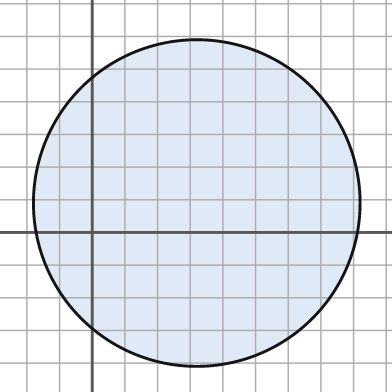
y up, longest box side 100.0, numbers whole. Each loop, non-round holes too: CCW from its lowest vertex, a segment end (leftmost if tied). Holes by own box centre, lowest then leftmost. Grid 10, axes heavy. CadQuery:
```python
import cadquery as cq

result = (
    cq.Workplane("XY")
    .moveTo(32.0, 9.0)
    .circle(50.0)
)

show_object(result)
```